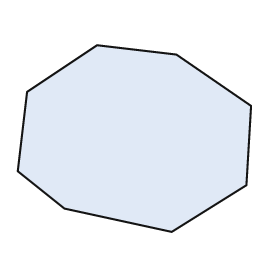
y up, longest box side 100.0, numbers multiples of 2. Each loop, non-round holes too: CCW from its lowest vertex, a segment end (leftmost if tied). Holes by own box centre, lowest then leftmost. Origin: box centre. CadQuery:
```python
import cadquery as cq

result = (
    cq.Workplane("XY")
    .moveTo(16.0, -40.0)
    .lineTo(48.0, -20.0)
    .lineTo(50.0, 14.0)
    .lineTo(18.0, 36.0)
    .lineTo(-16.0, 40.0)
    .lineTo(-46.0, 20.0)
    .lineTo(-50.0, -14.0)
    .lineTo(-30.0, -30.0)
    .close()
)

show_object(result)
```